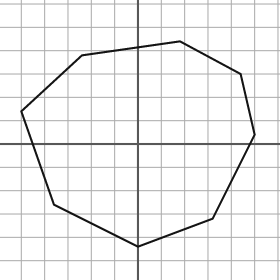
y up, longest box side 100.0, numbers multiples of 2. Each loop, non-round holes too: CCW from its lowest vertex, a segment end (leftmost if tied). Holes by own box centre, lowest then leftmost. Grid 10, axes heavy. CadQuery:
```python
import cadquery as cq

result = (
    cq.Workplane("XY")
    .moveTo(0.0, -44.0)
    .lineTo(32.0, -32.0)
    .lineTo(50.0, 4.0)
    .lineTo(44.0, 30.0)
    .lineTo(18.0, 44.0)
    .lineTo(-24.0, 38.0)
    .lineTo(-50.0, 14.0)
    .lineTo(-36.0, -26.0)
    .close()
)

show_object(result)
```